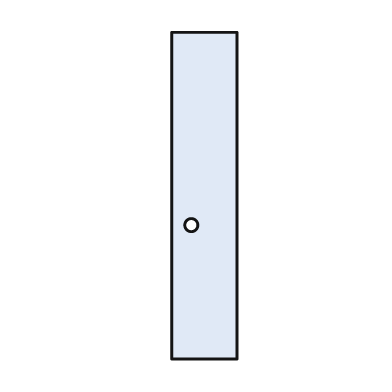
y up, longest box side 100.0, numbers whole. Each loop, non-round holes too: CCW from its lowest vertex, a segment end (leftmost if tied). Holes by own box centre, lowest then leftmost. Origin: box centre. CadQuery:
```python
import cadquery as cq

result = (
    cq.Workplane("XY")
    .moveTo(-10.0, -50.0)
    .lineTo(10.0, -50.0)
    .lineTo(10.0, 50.0)
    .lineTo(-10.0, 50.0)
    .close()
    .moveTo(-4.0, -9.0)
    .circle(2.0)
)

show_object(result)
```